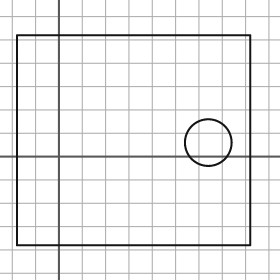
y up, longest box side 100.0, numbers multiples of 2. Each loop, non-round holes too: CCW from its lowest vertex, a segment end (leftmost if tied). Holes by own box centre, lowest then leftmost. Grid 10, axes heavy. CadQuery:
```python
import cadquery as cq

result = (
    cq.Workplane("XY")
    .moveTo(-18.0, -38.0)
    .lineTo(82.0, -38.0)
    .lineTo(82.0, 52.0)
    .lineTo(-18.0, 52.0)
    .close()
    .moveTo(64.0, 6.0)
    .circle(10.0)
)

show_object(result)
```